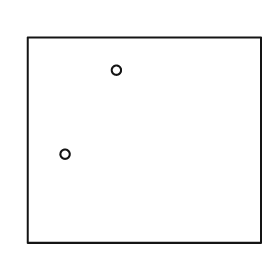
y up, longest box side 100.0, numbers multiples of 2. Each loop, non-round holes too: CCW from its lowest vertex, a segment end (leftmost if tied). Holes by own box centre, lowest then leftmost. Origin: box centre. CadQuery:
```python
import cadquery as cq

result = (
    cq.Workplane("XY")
    .moveTo(-50.0, -44.0)
    .lineTo(50.0, -44.0)
    .lineTo(50.0, 44.0)
    .lineTo(-50.0, 44.0)
    .close()
    .moveTo(-34.0, -6.0)
    .circle(2.0)
    .moveTo(-12.0, 30.0)
    .circle(2.0)
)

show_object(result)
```